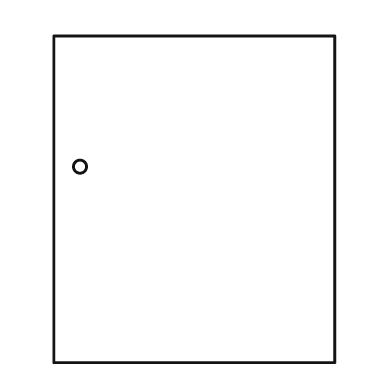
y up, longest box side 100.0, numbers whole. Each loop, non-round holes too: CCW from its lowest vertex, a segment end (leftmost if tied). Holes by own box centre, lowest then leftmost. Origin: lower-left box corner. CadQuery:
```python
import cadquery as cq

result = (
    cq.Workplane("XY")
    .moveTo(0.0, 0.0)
    .lineTo(86.0, 0.0)
    .lineTo(86.0, 100.0)
    .lineTo(0.0, 100.0)
    .close()
    .moveTo(8.0, 60.0)
    .circle(2.0)
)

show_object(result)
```